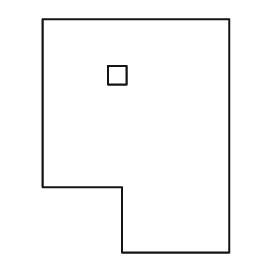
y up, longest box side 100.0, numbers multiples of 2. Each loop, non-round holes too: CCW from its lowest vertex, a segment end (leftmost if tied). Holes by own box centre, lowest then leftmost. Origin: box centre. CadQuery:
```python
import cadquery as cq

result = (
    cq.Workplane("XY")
    .moveTo(-6.0, -50.0)
    .lineTo(40.0, -50.0)
    .lineTo(40.0, 50.0)
    .lineTo(-40.0, 50.0)
    .lineTo(-40.0, -22.0)
    .lineTo(-6.0, -22.0)
    .close()
    .moveTo(-12.0, 22.0)
    .lineTo(-4.0, 22.0)
    .lineTo(-4.0, 30.0)
    .lineTo(-12.0, 30.0)
    .close()
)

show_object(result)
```